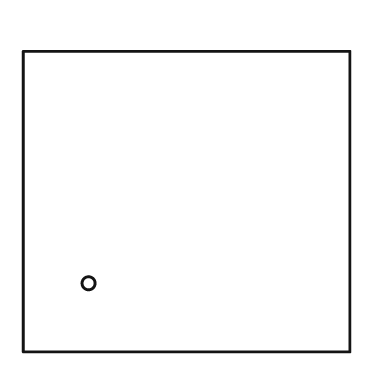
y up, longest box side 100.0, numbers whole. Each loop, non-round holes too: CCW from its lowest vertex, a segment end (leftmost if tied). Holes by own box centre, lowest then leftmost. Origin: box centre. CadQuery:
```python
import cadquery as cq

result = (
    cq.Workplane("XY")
    .moveTo(-50.0, -46.0)
    .lineTo(50.0, -46.0)
    .lineTo(50.0, 46.0)
    .lineTo(-50.0, 46.0)
    .close()
    .moveTo(-30.0, -25.0)
    .circle(2.0)
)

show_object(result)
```